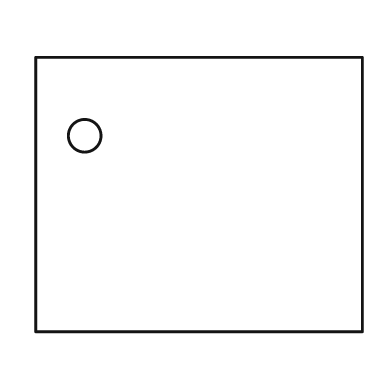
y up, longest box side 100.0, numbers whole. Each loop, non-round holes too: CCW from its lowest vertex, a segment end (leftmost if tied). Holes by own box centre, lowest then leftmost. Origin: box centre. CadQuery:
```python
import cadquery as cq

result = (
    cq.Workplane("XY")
    .moveTo(-50.0, -42.0)
    .lineTo(50.0, -42.0)
    .lineTo(50.0, 42.0)
    .lineTo(-50.0, 42.0)
    .close()
    .moveTo(-35.0, 18.0)
    .circle(5.0)
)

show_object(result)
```